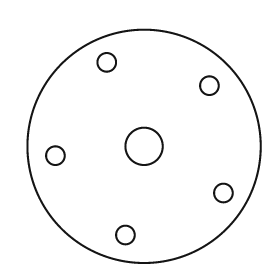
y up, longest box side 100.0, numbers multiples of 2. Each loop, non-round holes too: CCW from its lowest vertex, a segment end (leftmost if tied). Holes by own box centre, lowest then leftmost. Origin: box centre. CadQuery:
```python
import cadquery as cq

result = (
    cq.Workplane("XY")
    .moveTo(0.0, 0.0)
    .circle(50.0)
    .moveTo(-8.0, -38.0)
    .circle(4.0)
    .moveTo(34.0, -20.0)
    .circle(4.0)
    .moveTo(-38.0, -4.0)
    .circle(4.0)
    .moveTo(0.0, 0.0)
    .circle(8.0)
    .moveTo(28.0, 26.0)
    .circle(4.0)
    .moveTo(-16.0, 36.0)
    .circle(4.0)
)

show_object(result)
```